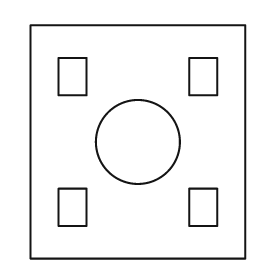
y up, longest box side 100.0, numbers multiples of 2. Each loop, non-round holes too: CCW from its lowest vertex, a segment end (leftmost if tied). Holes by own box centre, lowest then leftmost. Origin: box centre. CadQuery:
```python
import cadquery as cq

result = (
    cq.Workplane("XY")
    .moveTo(-46.0, -50.0)
    .lineTo(46.0, -50.0)
    .lineTo(46.0, 50.0)
    .lineTo(-46.0, 50.0)
    .close()
    .moveTo(-34.0, -36.0)
    .lineTo(-22.0, -36.0)
    .lineTo(-22.0, -20.0)
    .lineTo(-34.0, -20.0)
    .close()
    .moveTo(22.0, -36.0)
    .lineTo(34.0, -36.0)
    .lineTo(34.0, -20.0)
    .lineTo(22.0, -20.0)
    .close()
    .moveTo(0.0, 0.0)
    .circle(18.0)
    .moveTo(-34.0, 20.0)
    .lineTo(-22.0, 20.0)
    .lineTo(-22.0, 36.0)
    .lineTo(-34.0, 36.0)
    .close()
    .moveTo(22.0, 20.0)
    .lineTo(34.0, 20.0)
    .lineTo(34.0, 36.0)
    .lineTo(22.0, 36.0)
    .close()
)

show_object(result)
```